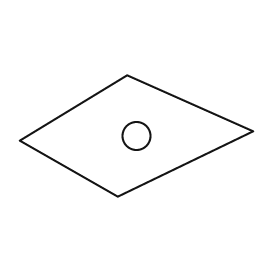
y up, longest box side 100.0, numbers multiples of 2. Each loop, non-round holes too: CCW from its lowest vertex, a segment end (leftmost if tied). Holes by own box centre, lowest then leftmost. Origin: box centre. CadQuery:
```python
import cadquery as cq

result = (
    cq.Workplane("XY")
    .moveTo(-8.0, -26.0)
    .lineTo(50.0, 2.0)
    .lineTo(-4.0, 26.0)
    .lineTo(-50.0, -2.0)
    .close()
    .moveTo(0.0, 0.0)
    .circle(6.0)
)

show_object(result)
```